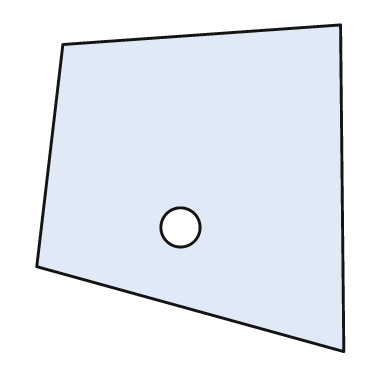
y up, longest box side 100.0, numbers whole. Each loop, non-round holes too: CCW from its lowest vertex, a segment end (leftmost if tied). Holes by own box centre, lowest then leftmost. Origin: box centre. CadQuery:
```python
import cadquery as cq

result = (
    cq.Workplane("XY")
    .moveTo(47.0, -50.0)
    .lineTo(46.0, 50.0)
    .lineTo(-39.0, 44.0)
    .lineTo(-47.0, -24.0)
    .close()
    .moveTo(-3.0, -12.0)
    .circle(6.0)
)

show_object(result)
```